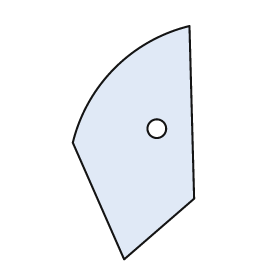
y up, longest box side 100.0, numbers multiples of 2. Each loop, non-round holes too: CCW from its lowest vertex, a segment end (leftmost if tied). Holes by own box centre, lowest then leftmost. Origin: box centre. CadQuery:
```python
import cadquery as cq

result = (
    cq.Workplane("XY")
    .moveTo(-4.0, -50.0)
    .lineTo(26.0, -24.0)
    .lineTo(24.0, 50.0)
    .threePointArc((-8.0, 32.0), (-26.0, 0.0))
    .close()
    .moveTo(10.0, 6.0)
    .circle(4.0)
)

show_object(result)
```